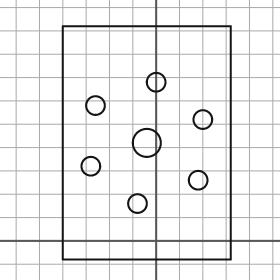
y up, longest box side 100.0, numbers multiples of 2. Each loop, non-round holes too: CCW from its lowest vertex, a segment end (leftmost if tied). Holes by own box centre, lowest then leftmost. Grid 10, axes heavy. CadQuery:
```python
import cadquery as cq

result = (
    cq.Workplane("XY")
    .moveTo(-40.0, -8.0)
    .lineTo(32.0, -8.0)
    .lineTo(32.0, 92.0)
    .lineTo(-40.0, 92.0)
    .close()
    .moveTo(-8.0, 16.0)
    .circle(4.0)
    .moveTo(18.0, 26.0)
    .circle(4.0)
    .moveTo(-28.0, 32.0)
    .circle(4.0)
    .moveTo(-4.0, 42.0)
    .circle(6.0)
    .moveTo(20.0, 52.0)
    .circle(4.0)
    .moveTo(-26.0, 58.0)
    .circle(4.0)
    .moveTo(0.0, 68.0)
    .circle(4.0)
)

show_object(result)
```